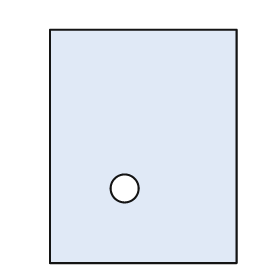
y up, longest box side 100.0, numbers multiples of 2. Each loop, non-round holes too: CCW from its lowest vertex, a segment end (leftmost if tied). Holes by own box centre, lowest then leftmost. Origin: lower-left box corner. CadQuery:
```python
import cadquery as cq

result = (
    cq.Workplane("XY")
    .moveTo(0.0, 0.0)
    .lineTo(80.0, 0.0)
    .lineTo(80.0, 100.0)
    .lineTo(0.0, 100.0)
    .close()
    .moveTo(32.0, 32.0)
    .circle(6.0)
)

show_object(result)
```